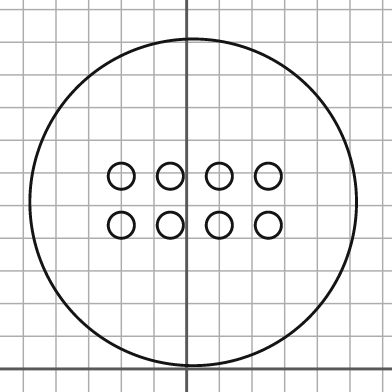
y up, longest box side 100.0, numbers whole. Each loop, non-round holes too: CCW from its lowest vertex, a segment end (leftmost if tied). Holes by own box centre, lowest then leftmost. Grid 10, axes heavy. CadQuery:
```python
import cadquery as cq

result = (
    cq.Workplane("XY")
    .moveTo(2.0, 51.0)
    .circle(50.0)
    .moveTo(-20.0, 44.0)
    .circle(4.0)
    .moveTo(-5.0, 44.0)
    .circle(4.0)
    .moveTo(10.0, 44.0)
    .circle(4.0)
    .moveTo(25.0, 44.0)
    .circle(4.0)
    .moveTo(-20.0, 59.0)
    .circle(4.0)
    .moveTo(-5.0, 59.0)
    .circle(4.0)
    .moveTo(10.0, 59.0)
    .circle(4.0)
    .moveTo(25.0, 59.0)
    .circle(4.0)
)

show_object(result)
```